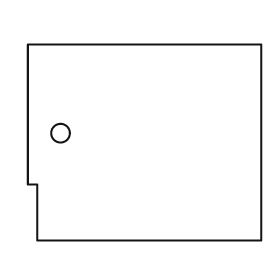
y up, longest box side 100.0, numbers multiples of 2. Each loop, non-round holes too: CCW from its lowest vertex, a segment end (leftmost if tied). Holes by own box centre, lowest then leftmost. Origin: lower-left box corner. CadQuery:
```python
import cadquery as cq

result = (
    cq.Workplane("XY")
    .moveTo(4.0, 0.0)
    .lineTo(100.0, 0.0)
    .lineTo(100.0, 84.0)
    .lineTo(0.0, 84.0)
    .lineTo(0.0, 24.0)
    .lineTo(4.0, 24.0)
    .close()
    .moveTo(14.0, 46.0)
    .circle(4.0)
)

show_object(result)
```